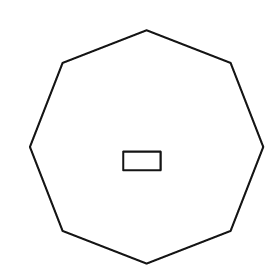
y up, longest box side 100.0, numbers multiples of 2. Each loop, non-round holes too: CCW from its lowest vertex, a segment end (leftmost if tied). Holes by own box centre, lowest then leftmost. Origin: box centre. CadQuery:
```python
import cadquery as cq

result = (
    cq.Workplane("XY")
    .moveTo(0.0, -50.0)
    .lineTo(36.0, -36.0)
    .lineTo(50.0, 0.0)
    .lineTo(36.0, 36.0)
    .lineTo(0.0, 50.0)
    .lineTo(-36.0, 36.0)
    .lineTo(-50.0, 0.0)
    .lineTo(-36.0, -36.0)
    .close()
    .moveTo(-10.0, -10.0)
    .lineTo(6.0, -10.0)
    .lineTo(6.0, -2.0)
    .lineTo(-10.0, -2.0)
    .close()
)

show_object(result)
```